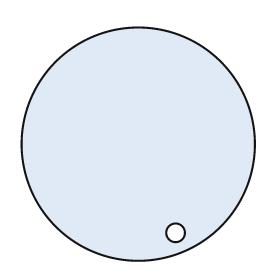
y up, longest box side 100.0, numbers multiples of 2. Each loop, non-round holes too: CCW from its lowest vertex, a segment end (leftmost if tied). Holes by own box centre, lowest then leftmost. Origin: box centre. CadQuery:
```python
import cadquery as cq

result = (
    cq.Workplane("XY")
    .moveTo(0.0, 0.0)
    .circle(50.0)
    .moveTo(16.0, -38.0)
    .circle(4.0)
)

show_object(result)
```